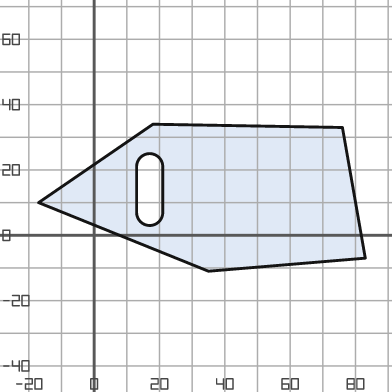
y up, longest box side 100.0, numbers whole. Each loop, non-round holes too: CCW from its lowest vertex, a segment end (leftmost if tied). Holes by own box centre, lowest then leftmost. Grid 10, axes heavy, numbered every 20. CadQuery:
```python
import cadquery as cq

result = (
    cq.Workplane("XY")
    .moveTo(35.0, -11.0)
    .lineTo(83.0, -7.0)
    .lineTo(76.0, 33.0)
    .lineTo(18.0, 34.0)
    .lineTo(-17.0, 10.0)
    .close()
    .moveTo(13.0, 7.0)
    .threePointArc((17.0, 3.0), (21.0, 7.0))
    .lineTo(21.0, 21.0)
    .threePointArc((17.0, 25.0), (13.0, 21.0))
    .close()
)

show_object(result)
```